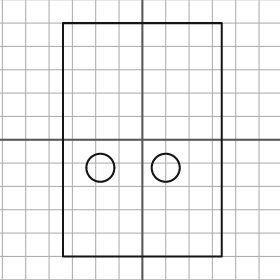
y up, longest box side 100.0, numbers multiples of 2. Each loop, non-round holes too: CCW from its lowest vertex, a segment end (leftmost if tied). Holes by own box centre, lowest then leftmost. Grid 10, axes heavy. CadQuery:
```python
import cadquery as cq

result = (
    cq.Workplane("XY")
    .moveTo(-34.0, -50.0)
    .lineTo(34.0, -50.0)
    .lineTo(34.0, 50.0)
    .lineTo(-34.0, 50.0)
    .close()
    .moveTo(-18.0, -12.0)
    .circle(6.0)
    .moveTo(10.0, -12.0)
    .circle(6.0)
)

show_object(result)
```